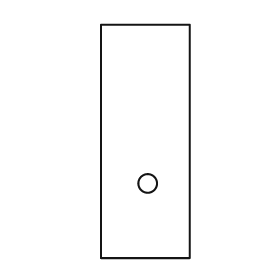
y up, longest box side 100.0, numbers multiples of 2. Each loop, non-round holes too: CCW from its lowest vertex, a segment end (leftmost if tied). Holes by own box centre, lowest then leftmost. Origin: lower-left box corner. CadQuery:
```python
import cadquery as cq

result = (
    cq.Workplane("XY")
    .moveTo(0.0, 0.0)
    .lineTo(38.0, 0.0)
    .lineTo(38.0, 100.0)
    .lineTo(0.0, 100.0)
    .close()
    .moveTo(20.0, 32.0)
    .circle(4.0)
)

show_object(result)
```